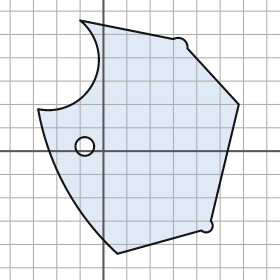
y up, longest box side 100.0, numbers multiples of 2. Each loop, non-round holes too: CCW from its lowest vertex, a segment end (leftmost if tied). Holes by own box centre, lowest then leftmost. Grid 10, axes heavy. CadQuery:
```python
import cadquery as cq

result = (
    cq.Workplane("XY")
    .moveTo(6.0, -44.0)
    .lineTo(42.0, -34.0)
    .threePointArc((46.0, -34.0), (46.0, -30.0))
    .lineTo(58.0, 20.0)
    .lineTo(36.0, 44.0)
    .threePointArc((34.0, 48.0), (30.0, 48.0))
    .lineTo(-10.0, 56.0)
    .threePointArc((-4.0, 30.0), (-28.0, 18.0))
    .threePointArc((-16.0, -16.0), (6.0, -44.0))
    .close()
    .moveTo(-8.0, 2.0)
    .circle(4.0)
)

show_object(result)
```